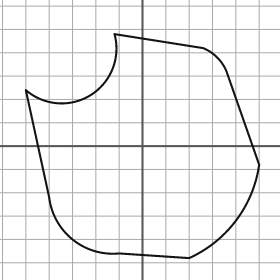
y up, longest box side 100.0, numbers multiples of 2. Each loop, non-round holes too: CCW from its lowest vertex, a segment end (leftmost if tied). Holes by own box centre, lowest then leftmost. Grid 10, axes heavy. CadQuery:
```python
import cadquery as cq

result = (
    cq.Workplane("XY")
    .moveTo(20.0, -48.0)
    .threePointArc((40.0, -32.0), (50.0, -8.0))
    .lineTo(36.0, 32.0)
    .threePointArc((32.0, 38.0), (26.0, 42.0))
    .lineTo(-12.0, 48.0)
    .threePointArc((-22.0, 22.0), (-50.0, 24.0))
    .lineTo(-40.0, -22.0)
    .threePointArc((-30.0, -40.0), (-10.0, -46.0))
    .close()
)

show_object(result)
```